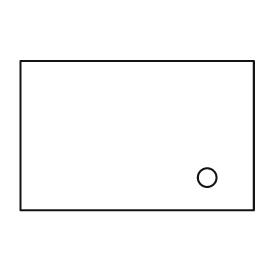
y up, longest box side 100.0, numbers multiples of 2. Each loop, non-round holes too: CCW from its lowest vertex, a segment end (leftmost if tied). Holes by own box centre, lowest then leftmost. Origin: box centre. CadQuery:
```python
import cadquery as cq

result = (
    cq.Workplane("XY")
    .moveTo(-50.0, -32.0)
    .lineTo(50.0, -32.0)
    .lineTo(50.0, 32.0)
    .lineTo(-50.0, 32.0)
    .close()
    .moveTo(30.0, -18.0)
    .circle(4.0)
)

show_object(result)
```